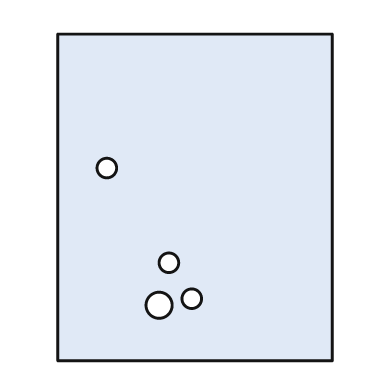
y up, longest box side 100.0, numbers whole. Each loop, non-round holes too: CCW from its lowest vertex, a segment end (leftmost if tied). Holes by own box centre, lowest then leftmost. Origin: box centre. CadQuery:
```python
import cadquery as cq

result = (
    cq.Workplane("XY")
    .moveTo(-42.0, -50.0)
    .lineTo(42.0, -50.0)
    .lineTo(42.0, 50.0)
    .lineTo(-42.0, 50.0)
    .close()
    .moveTo(-11.0, -33.0)
    .circle(4.0)
    .moveTo(-1.0, -31.0)
    .circle(3.0)
    .moveTo(-8.0, -20.0)
    .circle(3.0)
    .moveTo(-27.0, 9.0)
    .circle(3.0)
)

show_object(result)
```